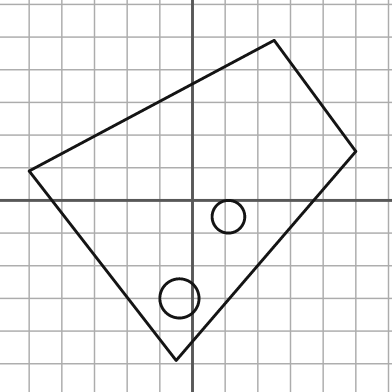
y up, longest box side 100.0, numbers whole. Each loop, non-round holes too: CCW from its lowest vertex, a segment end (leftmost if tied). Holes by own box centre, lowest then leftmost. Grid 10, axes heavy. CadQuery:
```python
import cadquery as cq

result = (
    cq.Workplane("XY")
    .moveTo(-5.0, -49.0)
    .lineTo(50.0, 15.0)
    .lineTo(25.0, 49.0)
    .lineTo(-50.0, 9.0)
    .close()
    .moveTo(-4.0, -30.0)
    .circle(6.0)
    .moveTo(11.0, -5.0)
    .circle(5.0)
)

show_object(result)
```